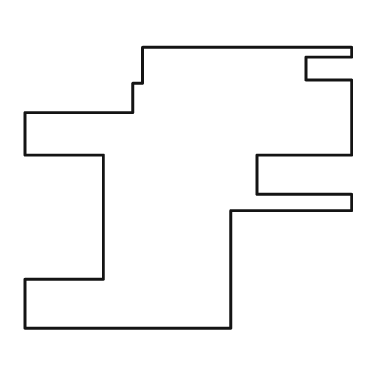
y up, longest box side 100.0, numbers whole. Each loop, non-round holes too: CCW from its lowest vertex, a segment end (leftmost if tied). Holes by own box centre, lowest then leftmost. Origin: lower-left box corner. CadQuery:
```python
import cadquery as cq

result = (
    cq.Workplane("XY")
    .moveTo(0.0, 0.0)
    .lineTo(63.0, 0.0)
    .lineTo(63.0, 36.0)
    .lineTo(100.0, 36.0)
    .lineTo(100.0, 41.0)
    .lineTo(71.0, 41.0)
    .lineTo(71.0, 53.0)
    .lineTo(100.0, 53.0)
    .lineTo(100.0, 76.0)
    .lineTo(86.0, 76.0)
    .lineTo(86.0, 83.0)
    .lineTo(100.0, 83.0)
    .lineTo(100.0, 86.0)
    .lineTo(36.0, 86.0)
    .lineTo(36.0, 75.0)
    .lineTo(33.0, 75.0)
    .lineTo(33.0, 66.0)
    .lineTo(0.0, 66.0)
    .lineTo(0.0, 53.0)
    .lineTo(24.0, 53.0)
    .lineTo(24.0, 15.0)
    .lineTo(0.0, 15.0)
    .close()
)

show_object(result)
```